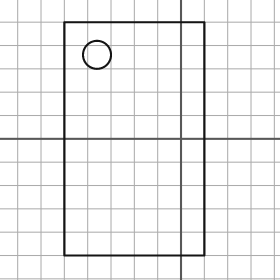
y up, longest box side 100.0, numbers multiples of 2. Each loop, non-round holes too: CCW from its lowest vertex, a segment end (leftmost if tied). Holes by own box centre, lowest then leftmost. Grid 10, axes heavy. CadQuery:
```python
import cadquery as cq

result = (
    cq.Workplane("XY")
    .moveTo(-50.0, -50.0)
    .lineTo(10.0, -50.0)
    .lineTo(10.0, 50.0)
    .lineTo(-50.0, 50.0)
    .close()
    .moveTo(-36.0, 36.0)
    .circle(6.0)
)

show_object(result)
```